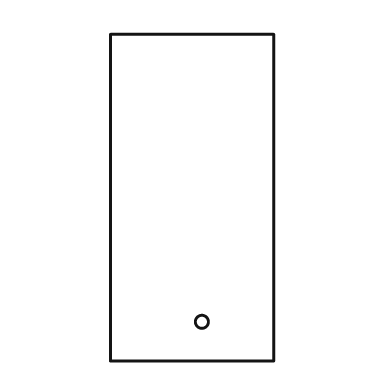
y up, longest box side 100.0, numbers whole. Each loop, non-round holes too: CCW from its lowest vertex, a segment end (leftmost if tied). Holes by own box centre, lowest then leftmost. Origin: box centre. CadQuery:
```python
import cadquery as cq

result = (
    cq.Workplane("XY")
    .moveTo(-25.0, -50.0)
    .lineTo(25.0, -50.0)
    .lineTo(25.0, 50.0)
    .lineTo(-25.0, 50.0)
    .close()
    .moveTo(3.0, -38.0)
    .circle(2.0)
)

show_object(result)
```